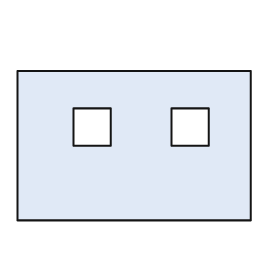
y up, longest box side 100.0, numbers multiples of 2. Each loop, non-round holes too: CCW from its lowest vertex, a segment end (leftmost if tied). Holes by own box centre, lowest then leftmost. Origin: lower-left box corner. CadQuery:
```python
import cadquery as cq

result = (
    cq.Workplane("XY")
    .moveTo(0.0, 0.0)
    .lineTo(100.0, 0.0)
    .lineTo(100.0, 64.0)
    .lineTo(0.0, 64.0)
    .close()
    .moveTo(24.0, 32.0)
    .lineTo(40.0, 32.0)
    .lineTo(40.0, 48.0)
    .lineTo(24.0, 48.0)
    .close()
    .moveTo(66.0, 32.0)
    .lineTo(82.0, 32.0)
    .lineTo(82.0, 48.0)
    .lineTo(66.0, 48.0)
    .close()
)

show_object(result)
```